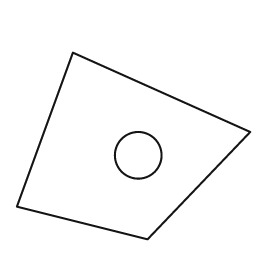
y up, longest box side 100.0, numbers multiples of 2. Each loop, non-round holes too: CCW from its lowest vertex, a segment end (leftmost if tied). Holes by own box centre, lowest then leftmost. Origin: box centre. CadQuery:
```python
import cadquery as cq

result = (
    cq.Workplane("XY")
    .moveTo(6.0, -40.0)
    .lineTo(50.0, 6.0)
    .lineTo(-26.0, 40.0)
    .lineTo(-50.0, -26.0)
    .close()
    .moveTo(2.0, -4.0)
    .circle(10.0)
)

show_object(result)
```